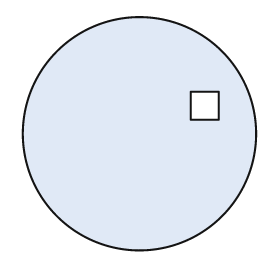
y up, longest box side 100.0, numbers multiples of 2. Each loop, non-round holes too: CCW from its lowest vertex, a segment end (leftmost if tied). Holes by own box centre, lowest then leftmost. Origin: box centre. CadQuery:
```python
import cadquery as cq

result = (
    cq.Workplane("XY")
    .moveTo(0.0, 0.0)
    .circle(50.0)
    .moveTo(22.0, 6.0)
    .lineTo(34.0, 6.0)
    .lineTo(34.0, 18.0)
    .lineTo(22.0, 18.0)
    .close()
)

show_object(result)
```